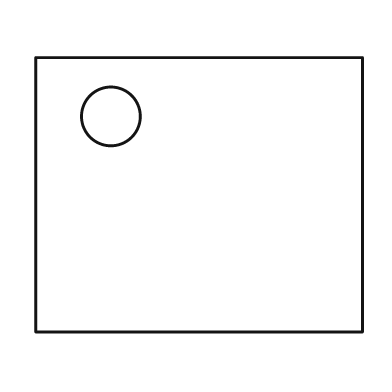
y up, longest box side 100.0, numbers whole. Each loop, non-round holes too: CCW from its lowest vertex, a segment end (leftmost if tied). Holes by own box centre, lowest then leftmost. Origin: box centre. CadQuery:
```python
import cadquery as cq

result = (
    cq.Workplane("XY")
    .moveTo(-50.0, -42.0)
    .lineTo(50.0, -42.0)
    .lineTo(50.0, 42.0)
    .lineTo(-50.0, 42.0)
    .close()
    .moveTo(-27.0, 24.0)
    .circle(9.0)
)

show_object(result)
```